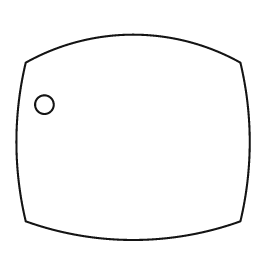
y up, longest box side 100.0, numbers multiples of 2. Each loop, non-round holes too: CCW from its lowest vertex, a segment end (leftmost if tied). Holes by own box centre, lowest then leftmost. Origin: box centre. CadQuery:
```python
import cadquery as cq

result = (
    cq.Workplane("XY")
    .moveTo(-46.0, -36.0)
    .threePointArc((0.0, -44.0), (46.0, -36.0))
    .threePointArc((50.0, -2.0), (46.0, 32.0))
    .threePointArc((0.0, 44.0), (-46.0, 32.0))
    .threePointArc((-50.0, -2.0), (-46.0, -36.0))
    .close()
    .moveTo(-38.0, 14.0)
    .circle(4.0)
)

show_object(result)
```